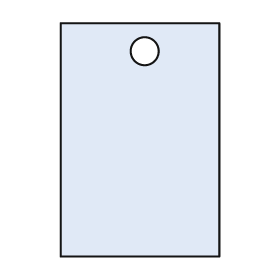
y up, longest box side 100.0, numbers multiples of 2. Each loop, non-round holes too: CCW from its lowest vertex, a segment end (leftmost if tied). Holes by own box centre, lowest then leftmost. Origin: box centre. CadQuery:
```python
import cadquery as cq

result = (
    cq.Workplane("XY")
    .moveTo(-34.0, -50.0)
    .lineTo(34.0, -50.0)
    .lineTo(34.0, 50.0)
    .lineTo(-34.0, 50.0)
    .close()
    .moveTo(2.0, 38.0)
    .circle(6.0)
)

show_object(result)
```